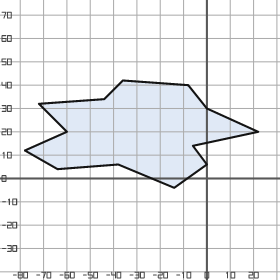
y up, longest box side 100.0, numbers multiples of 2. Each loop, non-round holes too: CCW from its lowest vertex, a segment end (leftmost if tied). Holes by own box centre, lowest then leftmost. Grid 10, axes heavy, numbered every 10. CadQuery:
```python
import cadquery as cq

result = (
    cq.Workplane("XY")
    .moveTo(-14.0, -4.0)
    .lineTo(0.0, 6.0)
    .lineTo(-6.0, 14.0)
    .lineTo(22.0, 20.0)
    .lineTo(0.0, 30.0)
    .lineTo(-8.0, 40.0)
    .lineTo(-36.0, 42.0)
    .lineTo(-44.0, 34.0)
    .lineTo(-72.0, 32.0)
    .lineTo(-60.0, 20.0)
    .lineTo(-78.0, 12.0)
    .lineTo(-64.0, 4.0)
    .lineTo(-38.0, 6.0)
    .close()
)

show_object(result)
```